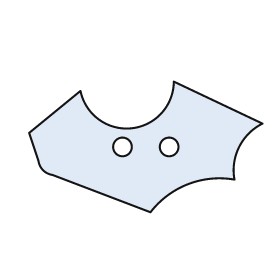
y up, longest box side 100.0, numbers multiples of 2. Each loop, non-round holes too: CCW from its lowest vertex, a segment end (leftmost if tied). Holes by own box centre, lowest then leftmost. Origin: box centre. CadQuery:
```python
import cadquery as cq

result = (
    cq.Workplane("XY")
    .moveTo(2.0, -28.0)
    .threePointArc((18.0, -16.0), (38.0, -14.0))
    .threePointArc((40.0, 0.0), (50.0, 10.0))
    .lineTo(12.0, 28.0)
    .threePointArc((-6.0, 8.0), (-28.0, 24.0))
    .lineTo(-50.0, 6.0)
    .lineTo(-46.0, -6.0)
    .threePointArc((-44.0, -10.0), (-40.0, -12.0))
    .close()
    .moveTo(-10.0, 0.0)
    .circle(4.0)
    .moveTo(10.0, 0.0)
    .circle(4.0)
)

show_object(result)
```